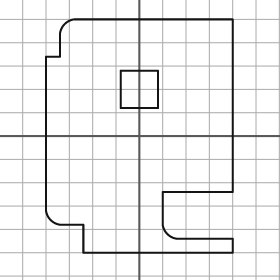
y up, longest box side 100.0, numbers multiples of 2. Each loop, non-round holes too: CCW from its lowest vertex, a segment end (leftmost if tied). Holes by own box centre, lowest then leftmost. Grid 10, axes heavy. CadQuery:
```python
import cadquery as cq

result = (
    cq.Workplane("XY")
    .moveTo(-24.0, -50.0)
    .lineTo(40.0, -50.0)
    .lineTo(40.0, -44.0)
    .lineTo(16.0, -44.0)
    .threePointArc((12.0, -42.0), (10.0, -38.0))
    .lineTo(10.0, -24.0)
    .lineTo(40.0, -24.0)
    .lineTo(40.0, 50.0)
    .lineTo(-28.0, 50.0)
    .threePointArc((-32.0, 48.0), (-34.0, 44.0))
    .lineTo(-34.0, 34.0)
    .lineTo(-40.0, 34.0)
    .lineTo(-40.0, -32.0)
    .threePointArc((-38.0, -36.0), (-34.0, -38.0))
    .lineTo(-24.0, -38.0)
    .close()
    .moveTo(-8.0, 12.0)
    .lineTo(8.0, 12.0)
    .lineTo(8.0, 28.0)
    .lineTo(-8.0, 28.0)
    .close()
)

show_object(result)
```